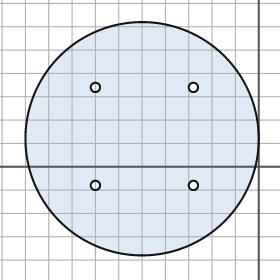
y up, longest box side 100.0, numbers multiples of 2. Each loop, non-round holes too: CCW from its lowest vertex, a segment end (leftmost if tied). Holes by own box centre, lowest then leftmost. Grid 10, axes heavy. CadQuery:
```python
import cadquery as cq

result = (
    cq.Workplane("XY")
    .moveTo(-50.0, 12.0)
    .circle(50.0)
    .moveTo(-70.0, -8.0)
    .circle(2.0)
    .moveTo(-28.0, -8.0)
    .circle(2.0)
    .moveTo(-70.0, 34.0)
    .circle(2.0)
    .moveTo(-28.0, 34.0)
    .circle(2.0)
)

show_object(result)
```